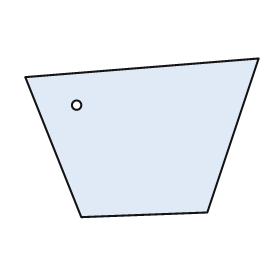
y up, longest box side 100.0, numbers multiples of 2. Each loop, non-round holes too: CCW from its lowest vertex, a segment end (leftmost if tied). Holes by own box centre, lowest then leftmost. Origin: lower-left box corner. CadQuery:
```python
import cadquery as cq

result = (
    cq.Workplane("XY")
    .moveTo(24.0, 0.0)
    .lineTo(78.0, 2.0)
    .lineTo(100.0, 68.0)
    .lineTo(0.0, 60.0)
    .close()
    .moveTo(22.0, 48.0)
    .circle(2.0)
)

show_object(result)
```